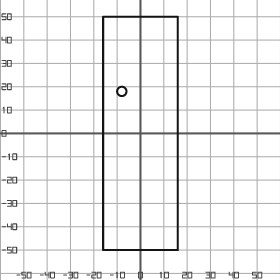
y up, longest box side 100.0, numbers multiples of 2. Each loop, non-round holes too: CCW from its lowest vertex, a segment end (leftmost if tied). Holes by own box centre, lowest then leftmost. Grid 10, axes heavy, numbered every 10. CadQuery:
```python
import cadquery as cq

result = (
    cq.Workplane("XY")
    .moveTo(-16.0, -50.0)
    .lineTo(16.0, -50.0)
    .lineTo(16.0, 50.0)
    .lineTo(-16.0, 50.0)
    .close()
    .moveTo(-8.0, 18.0)
    .circle(2.0)
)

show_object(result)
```